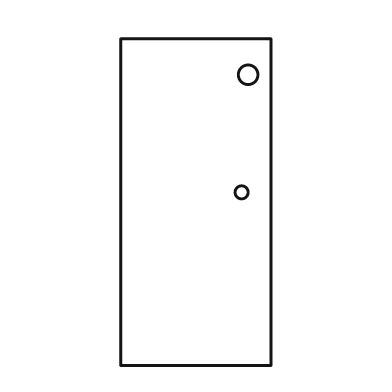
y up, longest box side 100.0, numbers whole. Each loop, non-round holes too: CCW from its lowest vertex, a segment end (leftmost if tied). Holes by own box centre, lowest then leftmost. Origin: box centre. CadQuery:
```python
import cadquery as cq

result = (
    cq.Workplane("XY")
    .moveTo(-23.0, -50.0)
    .lineTo(23.0, -50.0)
    .lineTo(23.0, 50.0)
    .lineTo(-23.0, 50.0)
    .close()
    .moveTo(14.0, 3.0)
    .circle(2.0)
    .moveTo(16.0, 39.0)
    .circle(3.0)
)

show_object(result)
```